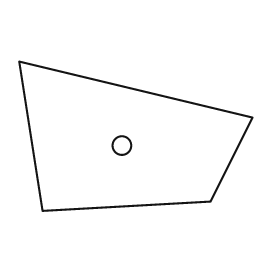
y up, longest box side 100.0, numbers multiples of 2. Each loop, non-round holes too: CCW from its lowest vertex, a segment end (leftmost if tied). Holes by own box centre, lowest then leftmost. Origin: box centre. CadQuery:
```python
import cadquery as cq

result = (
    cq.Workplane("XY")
    .moveTo(-40.0, -32.0)
    .lineTo(32.0, -28.0)
    .lineTo(50.0, 8.0)
    .lineTo(-50.0, 32.0)
    .close()
    .moveTo(-6.0, -4.0)
    .circle(4.0)
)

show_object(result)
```